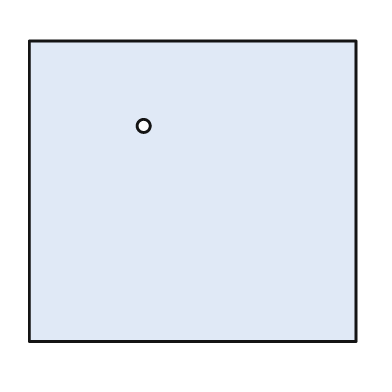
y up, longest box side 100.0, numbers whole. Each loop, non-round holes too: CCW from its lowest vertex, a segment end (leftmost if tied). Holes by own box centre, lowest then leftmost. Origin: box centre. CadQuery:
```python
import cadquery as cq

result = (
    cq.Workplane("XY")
    .moveTo(-50.0, -46.0)
    .lineTo(50.0, -46.0)
    .lineTo(50.0, 46.0)
    .lineTo(-50.0, 46.0)
    .close()
    .moveTo(-15.0, 20.0)
    .circle(2.0)
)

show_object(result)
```